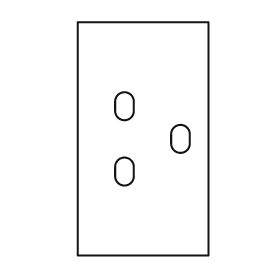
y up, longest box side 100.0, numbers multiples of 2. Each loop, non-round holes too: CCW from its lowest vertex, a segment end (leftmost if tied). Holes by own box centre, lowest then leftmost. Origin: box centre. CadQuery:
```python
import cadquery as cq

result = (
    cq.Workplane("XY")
    .moveTo(-28.0, -50.0)
    .lineTo(28.0, -50.0)
    .lineTo(28.0, 50.0)
    .lineTo(-28.0, 50.0)
    .close()
    .moveTo(-12.0, -16.0)
    .threePointArc((-8.0, -20.0), (-4.0, -16.0))
    .lineTo(-4.0, -12.0)
    .threePointArc((-8.0, -8.0), (-12.0, -12.0))
    .close()
    .moveTo(12.0, -2.0)
    .threePointArc((16.0, -6.0), (20.0, -2.0))
    .lineTo(20.0, 2.0)
    .threePointArc((16.0, 6.0), (12.0, 2.0))
    .close()
    .moveTo(-12.0, 12.0)
    .threePointArc((-8.0, 8.0), (-4.0, 12.0))
    .lineTo(-4.0, 16.0)
    .threePointArc((-8.0, 20.0), (-12.0, 16.0))
    .close()
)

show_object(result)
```